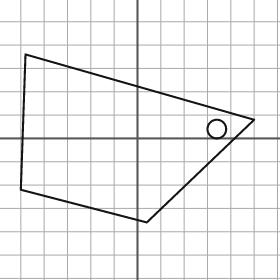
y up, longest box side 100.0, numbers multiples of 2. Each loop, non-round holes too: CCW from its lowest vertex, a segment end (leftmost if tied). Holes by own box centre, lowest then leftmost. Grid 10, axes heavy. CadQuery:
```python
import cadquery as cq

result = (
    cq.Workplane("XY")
    .moveTo(4.0, -36.0)
    .lineTo(50.0, 8.0)
    .lineTo(-48.0, 36.0)
    .lineTo(-50.0, -22.0)
    .close()
    .moveTo(34.0, 4.0)
    .circle(4.0)
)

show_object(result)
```